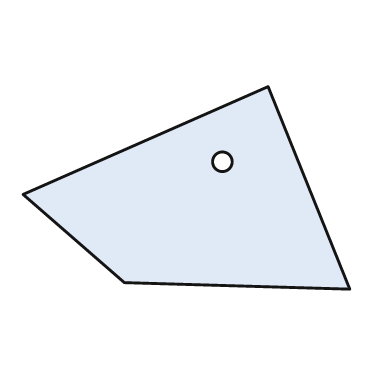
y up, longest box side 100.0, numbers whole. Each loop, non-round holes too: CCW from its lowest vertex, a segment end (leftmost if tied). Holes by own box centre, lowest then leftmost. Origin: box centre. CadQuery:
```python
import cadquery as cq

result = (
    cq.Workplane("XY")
    .moveTo(50.0, -31.0)
    .lineTo(25.0, 31.0)
    .lineTo(-50.0, -2.0)
    .lineTo(-19.0, -29.0)
    .close()
    .moveTo(11.0, 8.0)
    .circle(3.0)
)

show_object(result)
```